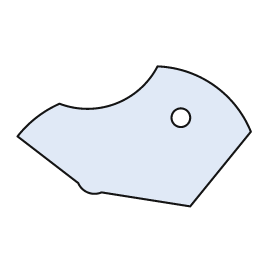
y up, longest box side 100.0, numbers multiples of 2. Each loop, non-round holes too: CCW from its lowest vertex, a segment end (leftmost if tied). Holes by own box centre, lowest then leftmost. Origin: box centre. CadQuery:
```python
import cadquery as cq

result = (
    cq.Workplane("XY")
    .moveTo(24.0, -30.0)
    .lineTo(50.0, 2.0)
    .threePointArc((34.0, 22.0), (10.0, 30.0))
    .threePointArc((-8.0, 14.0), (-32.0, 14.0))
    .threePointArc((-42.0, 8.0), (-50.0, 0.0))
    .lineTo(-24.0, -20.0)
    .threePointArc((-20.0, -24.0), (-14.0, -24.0))
    .close()
    .moveTo(20.0, 8.0)
    .circle(4.0)
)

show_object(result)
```